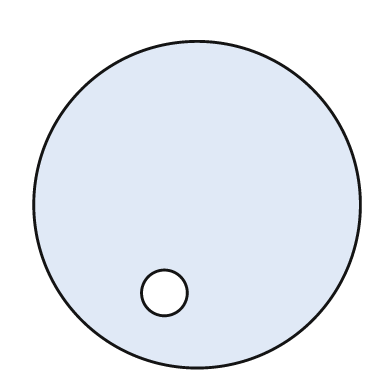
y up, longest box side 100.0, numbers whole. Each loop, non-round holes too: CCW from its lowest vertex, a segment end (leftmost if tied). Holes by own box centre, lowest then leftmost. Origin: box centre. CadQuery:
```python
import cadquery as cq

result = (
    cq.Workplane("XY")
    .moveTo(0.0, 0.0)
    .circle(50.0)
    .moveTo(-10.0, -27.0)
    .circle(7.0)
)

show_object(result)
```